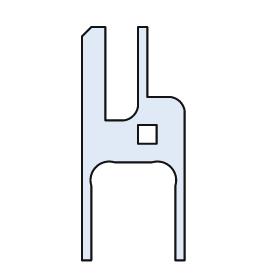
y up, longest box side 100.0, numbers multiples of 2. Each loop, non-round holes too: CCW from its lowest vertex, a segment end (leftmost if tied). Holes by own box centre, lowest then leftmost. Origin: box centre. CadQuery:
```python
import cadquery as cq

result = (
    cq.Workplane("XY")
    .moveTo(-22.0, -50.0)
    .lineTo(-18.0, -50.0)
    .lineTo(-18.0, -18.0)
    .threePointArc((-16.0, -10.0), (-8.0, -8.0))
    .lineTo(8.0, -8.0)
    .threePointArc((16.0, -10.0), (18.0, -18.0))
    .lineTo(18.0, -50.0)
    .lineTo(22.0, -50.0)
    .lineTo(22.0, 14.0)
    .threePointArc((20.0, 18.0), (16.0, 20.0))
    .lineTo(6.0, 20.0)
    .lineTo(6.0, 50.0)
    .lineTo(2.0, 50.0)
    .lineTo(2.0, 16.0)
    .threePointArc((0.0, 12.0), (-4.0, 10.0))
    .lineTo(-12.0, 10.0)
    .lineTo(-12.0, 50.0)
    .lineTo(-18.0, 50.0)
    .lineTo(-22.0, 46.0)
    .close()
    .moveTo(2.0, 0.0)
    .lineTo(10.0, 0.0)
    .lineTo(10.0, 8.0)
    .lineTo(2.0, 8.0)
    .close()
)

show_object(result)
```